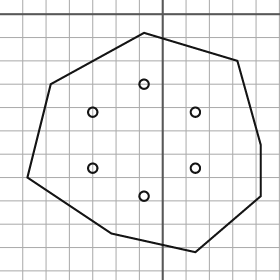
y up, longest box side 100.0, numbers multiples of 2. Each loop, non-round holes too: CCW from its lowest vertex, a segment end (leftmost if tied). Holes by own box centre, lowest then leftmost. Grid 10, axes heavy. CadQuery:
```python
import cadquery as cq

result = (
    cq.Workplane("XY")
    .moveTo(14.0, -102.0)
    .lineTo(42.0, -78.0)
    .lineTo(42.0, -56.0)
    .lineTo(32.0, -20.0)
    .lineTo(-8.0, -8.0)
    .lineTo(-48.0, -30.0)
    .lineTo(-58.0, -70.0)
    .lineTo(-22.0, -94.0)
    .close()
    .moveTo(-8.0, -78.0)
    .circle(2.0)
    .moveTo(-30.0, -66.0)
    .circle(2.0)
    .moveTo(14.0, -66.0)
    .circle(2.0)
    .moveTo(-30.0, -42.0)
    .circle(2.0)
    .moveTo(14.0, -42.0)
    .circle(2.0)
    .moveTo(-8.0, -30.0)
    .circle(2.0)
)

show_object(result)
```